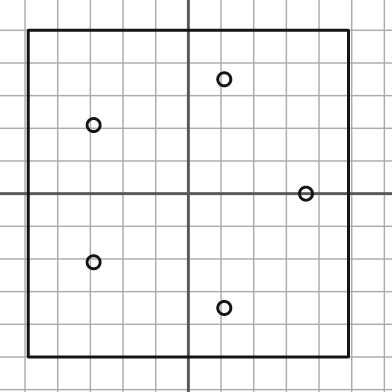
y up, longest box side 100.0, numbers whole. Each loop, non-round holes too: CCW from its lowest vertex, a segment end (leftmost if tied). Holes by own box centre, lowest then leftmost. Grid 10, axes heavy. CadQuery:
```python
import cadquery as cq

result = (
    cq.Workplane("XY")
    .moveTo(-49.0, -50.0)
    .lineTo(49.0, -50.0)
    .lineTo(49.0, 50.0)
    .lineTo(-49.0, 50.0)
    .close()
    .moveTo(11.0, -35.0)
    .circle(2.0)
    .moveTo(-29.0, -21.0)
    .circle(2.0)
    .moveTo(36.0, 0.0)
    .circle(2.0)
    .moveTo(-29.0, 21.0)
    .circle(2.0)
    .moveTo(11.0, 35.0)
    .circle(2.0)
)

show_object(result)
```